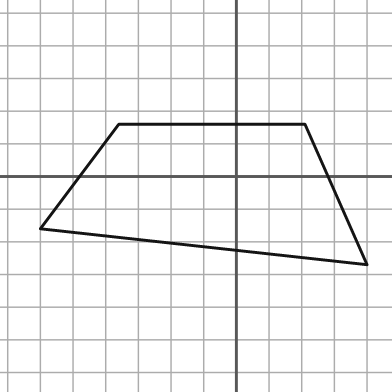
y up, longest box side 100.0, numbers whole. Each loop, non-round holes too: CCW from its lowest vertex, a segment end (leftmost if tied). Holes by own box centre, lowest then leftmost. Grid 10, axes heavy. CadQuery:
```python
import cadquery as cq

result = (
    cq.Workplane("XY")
    .moveTo(40.0, -27.0)
    .lineTo(21.0, 16.0)
    .lineTo(-36.0, 16.0)
    .lineTo(-60.0, -16.0)
    .close()
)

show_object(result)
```